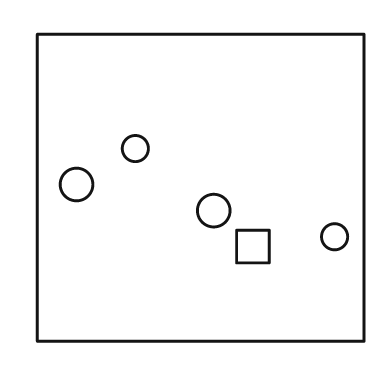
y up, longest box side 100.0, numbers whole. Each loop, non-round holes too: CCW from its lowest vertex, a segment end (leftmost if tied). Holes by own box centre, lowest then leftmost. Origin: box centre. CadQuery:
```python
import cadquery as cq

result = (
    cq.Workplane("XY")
    .moveTo(-50.0, -47.0)
    .lineTo(50.0, -47.0)
    .lineTo(50.0, 47.0)
    .lineTo(-50.0, 47.0)
    .close()
    .moveTo(11.0, -23.0)
    .lineTo(21.0, -23.0)
    .lineTo(21.0, -13.0)
    .lineTo(11.0, -13.0)
    .close()
    .moveTo(41.0, -15.0)
    .circle(4.0)
    .moveTo(4.0, -7.0)
    .circle(5.0)
    .moveTo(-38.0, 1.0)
    .circle(5.0)
    .moveTo(-20.0, 12.0)
    .circle(4.0)
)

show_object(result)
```